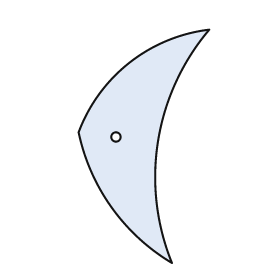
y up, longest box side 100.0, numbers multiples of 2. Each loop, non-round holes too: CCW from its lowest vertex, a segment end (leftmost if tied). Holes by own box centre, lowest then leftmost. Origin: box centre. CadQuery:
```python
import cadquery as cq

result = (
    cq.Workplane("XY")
    .moveTo(12.0, -50.0)
    .threePointArc((6.0, 2.0), (28.0, 50.0))
    .threePointArc((-6.0, 36.0), (-28.0, 6.0))
    .threePointArc((-14.0, -26.0), (12.0, -50.0))
    .close()
    .moveTo(-12.0, 4.0)
    .circle(2.0)
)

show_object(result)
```